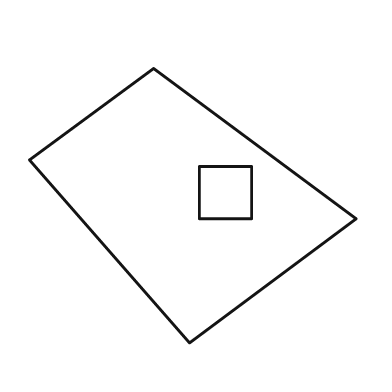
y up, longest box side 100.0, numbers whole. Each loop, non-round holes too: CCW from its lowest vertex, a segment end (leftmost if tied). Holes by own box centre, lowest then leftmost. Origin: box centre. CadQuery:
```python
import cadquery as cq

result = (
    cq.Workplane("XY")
    .moveTo(-1.0, -42.0)
    .lineTo(50.0, -4.0)
    .lineTo(-12.0, 42.0)
    .lineTo(-50.0, 14.0)
    .close()
    .moveTo(2.0, -4.0)
    .lineTo(18.0, -4.0)
    .lineTo(18.0, 12.0)
    .lineTo(2.0, 12.0)
    .close()
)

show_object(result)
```